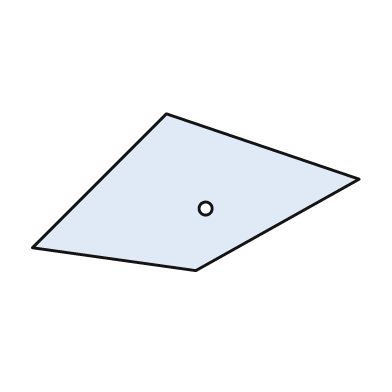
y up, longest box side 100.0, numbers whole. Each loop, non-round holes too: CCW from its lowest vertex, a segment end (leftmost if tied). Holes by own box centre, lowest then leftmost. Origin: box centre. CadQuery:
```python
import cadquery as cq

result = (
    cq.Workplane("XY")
    .moveTo(0.0, -24.0)
    .lineTo(50.0, 4.0)
    .lineTo(-9.0, 24.0)
    .lineTo(-50.0, -17.0)
    .close()
    .moveTo(3.0, -5.0)
    .circle(2.0)
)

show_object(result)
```